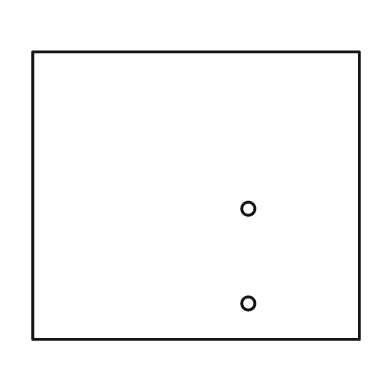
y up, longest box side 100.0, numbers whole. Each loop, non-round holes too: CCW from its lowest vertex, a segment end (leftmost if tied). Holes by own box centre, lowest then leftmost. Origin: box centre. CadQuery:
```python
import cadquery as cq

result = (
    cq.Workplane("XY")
    .moveTo(-50.0, -44.0)
    .lineTo(50.0, -44.0)
    .lineTo(50.0, 44.0)
    .lineTo(-50.0, 44.0)
    .close()
    .moveTo(16.0, -33.0)
    .circle(2.0)
    .moveTo(16.0, -4.0)
    .circle(2.0)
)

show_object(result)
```